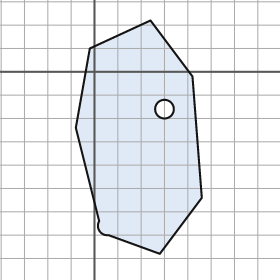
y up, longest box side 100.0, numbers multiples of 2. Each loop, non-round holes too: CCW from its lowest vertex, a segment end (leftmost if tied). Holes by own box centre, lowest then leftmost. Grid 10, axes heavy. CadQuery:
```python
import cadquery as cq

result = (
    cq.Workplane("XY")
    .moveTo(28.0, -78.0)
    .lineTo(46.0, -54.0)
    .lineTo(42.0, -2.0)
    .lineTo(24.0, 22.0)
    .lineTo(-2.0, 10.0)
    .lineTo(-8.0, -24.0)
    .lineTo(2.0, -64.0)
    .threePointArc((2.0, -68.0), (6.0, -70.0))
    .close()
    .moveTo(30.0, -16.0)
    .circle(4.0)
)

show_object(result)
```